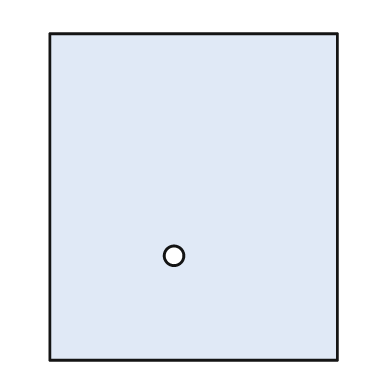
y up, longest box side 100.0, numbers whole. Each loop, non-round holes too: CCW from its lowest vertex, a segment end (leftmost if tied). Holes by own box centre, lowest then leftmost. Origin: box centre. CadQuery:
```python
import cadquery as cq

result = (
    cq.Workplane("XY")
    .moveTo(-44.0, -50.0)
    .lineTo(44.0, -50.0)
    .lineTo(44.0, 50.0)
    .lineTo(-44.0, 50.0)
    .close()
    .moveTo(-6.0, -18.0)
    .circle(3.0)
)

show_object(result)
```